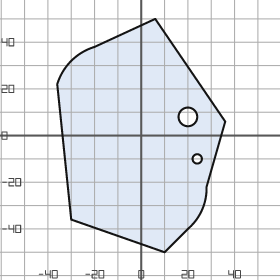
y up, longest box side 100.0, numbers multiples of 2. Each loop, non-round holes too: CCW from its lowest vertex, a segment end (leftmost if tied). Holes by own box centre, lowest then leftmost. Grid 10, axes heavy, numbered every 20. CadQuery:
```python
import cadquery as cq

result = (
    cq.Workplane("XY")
    .moveTo(10.0, -50.0)
    .lineTo(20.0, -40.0)
    .threePointArc((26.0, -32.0), (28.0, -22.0))
    .lineTo(36.0, 6.0)
    .lineTo(6.0, 50.0)
    .lineTo(-20.0, 38.0)
    .threePointArc((-30.0, 32.0), (-36.0, 22.0))
    .lineTo(-30.0, -36.0)
    .close()
    .moveTo(24.0, -10.0)
    .circle(2.0)
    .moveTo(20.0, 8.0)
    .circle(4.0)
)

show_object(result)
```